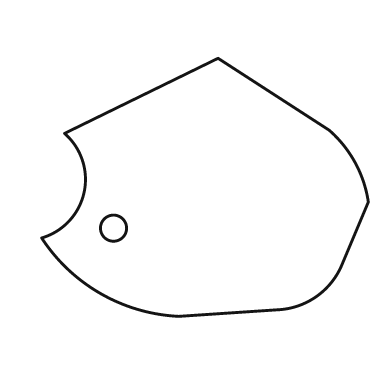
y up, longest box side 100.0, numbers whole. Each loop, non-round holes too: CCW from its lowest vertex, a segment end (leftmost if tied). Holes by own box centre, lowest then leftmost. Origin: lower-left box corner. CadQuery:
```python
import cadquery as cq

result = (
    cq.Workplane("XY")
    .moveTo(42.0, 0.0)
    .lineTo(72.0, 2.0)
    .threePointArc((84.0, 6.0), (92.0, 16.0))
    .lineTo(100.0, 35.0)
    .threePointArc((96.0, 47.0), (88.0, 57.0))
    .lineTo(54.0, 79.0)
    .lineTo(7.0, 56.0)
    .threePointArc((13.0, 38.0), (0.0, 24.0))
    .threePointArc((18.0, 7.0), (42.0, 0.0))
    .close()
    .moveTo(22.0, 27.0)
    .circle(4.0)
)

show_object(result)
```